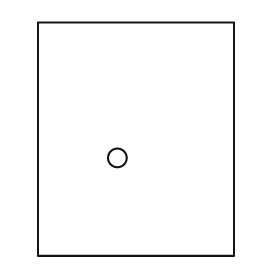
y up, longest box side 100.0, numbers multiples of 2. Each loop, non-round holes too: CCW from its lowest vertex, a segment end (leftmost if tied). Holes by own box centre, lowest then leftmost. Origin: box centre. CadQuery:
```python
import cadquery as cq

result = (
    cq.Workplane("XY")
    .moveTo(-42.0, -50.0)
    .lineTo(42.0, -50.0)
    .lineTo(42.0, 50.0)
    .lineTo(-42.0, 50.0)
    .close()
    .moveTo(-8.0, -8.0)
    .circle(4.0)
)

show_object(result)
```